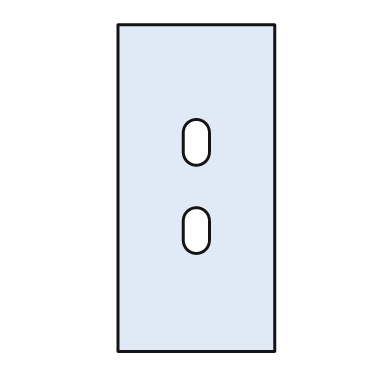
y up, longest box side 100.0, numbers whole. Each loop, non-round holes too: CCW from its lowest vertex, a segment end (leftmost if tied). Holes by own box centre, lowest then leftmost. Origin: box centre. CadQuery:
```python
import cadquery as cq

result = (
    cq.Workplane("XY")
    .moveTo(-24.0, -50.0)
    .lineTo(24.0, -50.0)
    .lineTo(24.0, 50.0)
    .lineTo(-24.0, 50.0)
    .close()
    .moveTo(-4.0, -16.0)
    .threePointArc((0.0, -20.0), (4.0, -16.0))
    .lineTo(4.0, -10.0)
    .threePointArc((0.0, -6.0), (-4.0, -10.0))
    .close()
    .moveTo(-4.0, 11.0)
    .threePointArc((0.0, 7.0), (4.0, 11.0))
    .lineTo(4.0, 17.0)
    .threePointArc((0.0, 21.0), (-4.0, 17.0))
    .close()
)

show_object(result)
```